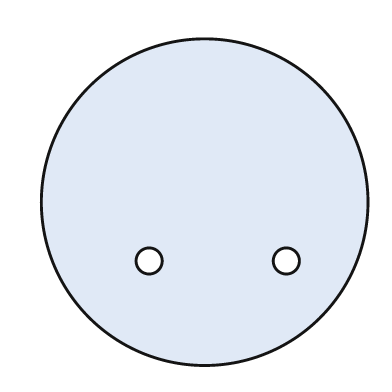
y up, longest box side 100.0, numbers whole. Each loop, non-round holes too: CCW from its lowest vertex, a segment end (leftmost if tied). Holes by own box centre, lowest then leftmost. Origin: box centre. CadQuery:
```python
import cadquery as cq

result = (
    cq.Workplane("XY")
    .moveTo(0.0, 0.0)
    .circle(50.0)
    .moveTo(-17.0, -18.0)
    .circle(4.0)
    .moveTo(25.0, -18.0)
    .circle(4.0)
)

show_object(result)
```